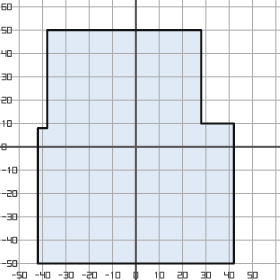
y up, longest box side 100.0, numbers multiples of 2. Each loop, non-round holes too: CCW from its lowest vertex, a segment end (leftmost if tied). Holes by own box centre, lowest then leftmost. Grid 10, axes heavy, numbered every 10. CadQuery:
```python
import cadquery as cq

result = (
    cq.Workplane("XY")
    .moveTo(-42.0, -50.0)
    .lineTo(42.0, -50.0)
    .lineTo(42.0, 10.0)
    .lineTo(28.0, 10.0)
    .lineTo(28.0, 50.0)
    .lineTo(-38.0, 50.0)
    .lineTo(-38.0, 8.0)
    .lineTo(-42.0, 8.0)
    .close()
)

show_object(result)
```